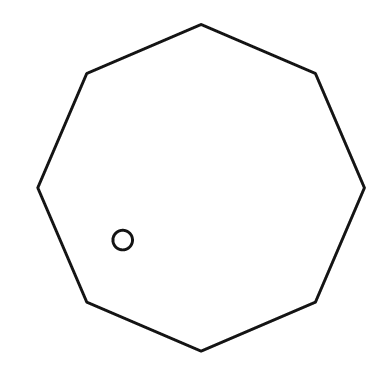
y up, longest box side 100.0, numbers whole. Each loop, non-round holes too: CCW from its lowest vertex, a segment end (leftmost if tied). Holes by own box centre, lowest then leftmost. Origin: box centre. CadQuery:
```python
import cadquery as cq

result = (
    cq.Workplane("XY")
    .moveTo(0.0, -50.0)
    .lineTo(35.0, -35.0)
    .lineTo(50.0, 0.0)
    .lineTo(35.0, 35.0)
    .lineTo(0.0, 50.0)
    .lineTo(-35.0, 35.0)
    .lineTo(-50.0, 0.0)
    .lineTo(-35.0, -35.0)
    .close()
    .moveTo(-24.0, -16.0)
    .circle(3.0)
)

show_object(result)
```